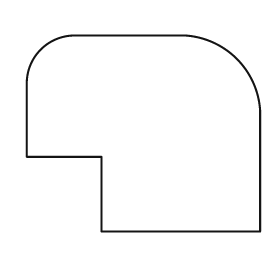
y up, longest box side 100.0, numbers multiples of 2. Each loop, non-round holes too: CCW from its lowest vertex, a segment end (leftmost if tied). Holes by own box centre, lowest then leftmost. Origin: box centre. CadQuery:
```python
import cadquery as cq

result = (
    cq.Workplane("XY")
    .moveTo(-18.0, -42.0)
    .lineTo(50.0, -42.0)
    .lineTo(50.0, 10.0)
    .threePointArc((40.0, 32.0), (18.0, 42.0))
    .lineTo(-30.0, 42.0)
    .threePointArc((-44.0, 36.0), (-50.0, 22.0))
    .lineTo(-50.0, -10.0)
    .lineTo(-18.0, -10.0)
    .close()
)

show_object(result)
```